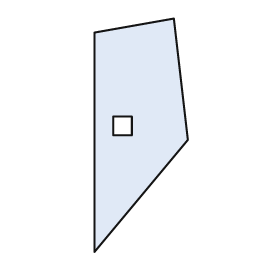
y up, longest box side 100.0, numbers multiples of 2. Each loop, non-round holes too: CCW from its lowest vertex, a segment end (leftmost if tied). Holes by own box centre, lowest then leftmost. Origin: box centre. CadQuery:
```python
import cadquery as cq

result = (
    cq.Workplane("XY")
    .moveTo(-20.0, -50.0)
    .lineTo(20.0, -2.0)
    .lineTo(14.0, 50.0)
    .lineTo(-20.0, 44.0)
    .close()
    .moveTo(-12.0, 0.0)
    .lineTo(-4.0, 0.0)
    .lineTo(-4.0, 8.0)
    .lineTo(-12.0, 8.0)
    .close()
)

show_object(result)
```